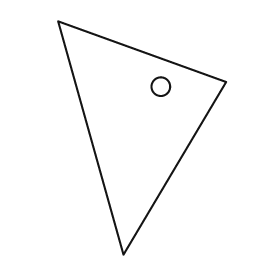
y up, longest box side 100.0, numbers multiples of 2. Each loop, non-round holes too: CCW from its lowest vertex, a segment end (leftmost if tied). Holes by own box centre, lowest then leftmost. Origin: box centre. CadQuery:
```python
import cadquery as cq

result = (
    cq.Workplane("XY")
    .moveTo(-8.0, -50.0)
    .lineTo(36.0, 24.0)
    .lineTo(-36.0, 50.0)
    .close()
    .moveTo(8.0, 22.0)
    .circle(4.0)
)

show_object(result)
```